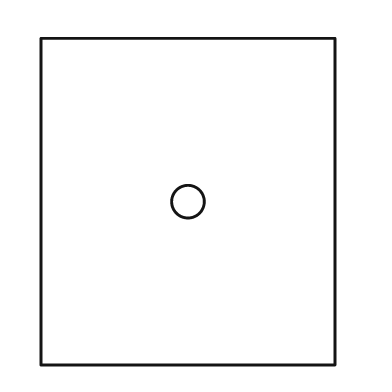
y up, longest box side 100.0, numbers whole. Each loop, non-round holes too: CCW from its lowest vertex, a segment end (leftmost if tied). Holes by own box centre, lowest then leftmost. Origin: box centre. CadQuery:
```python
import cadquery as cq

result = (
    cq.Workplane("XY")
    .moveTo(-45.0, -50.0)
    .lineTo(45.0, -50.0)
    .lineTo(45.0, 50.0)
    .lineTo(-45.0, 50.0)
    .close()
    .moveTo(0.0, 0.0)
    .circle(5.0)
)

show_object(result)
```